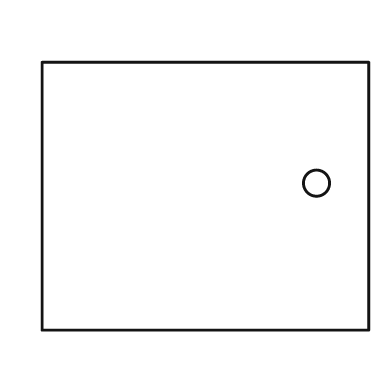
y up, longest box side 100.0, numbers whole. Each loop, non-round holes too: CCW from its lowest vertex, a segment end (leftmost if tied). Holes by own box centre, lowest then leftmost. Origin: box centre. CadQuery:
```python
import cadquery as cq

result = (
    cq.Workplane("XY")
    .moveTo(-50.0, -41.0)
    .lineTo(50.0, -41.0)
    .lineTo(50.0, 41.0)
    .lineTo(-50.0, 41.0)
    .close()
    .moveTo(34.0, 4.0)
    .circle(4.0)
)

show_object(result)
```